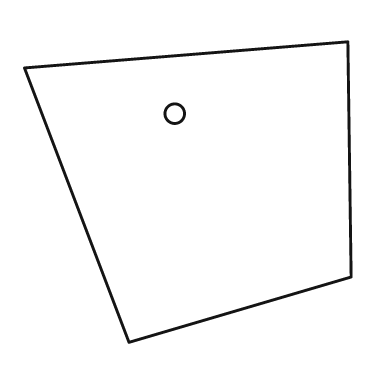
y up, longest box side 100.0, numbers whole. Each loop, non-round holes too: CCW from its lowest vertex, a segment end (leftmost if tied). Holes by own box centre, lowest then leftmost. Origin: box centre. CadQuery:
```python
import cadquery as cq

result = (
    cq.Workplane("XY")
    .moveTo(-18.0, -46.0)
    .lineTo(50.0, -26.0)
    .lineTo(49.0, 46.0)
    .lineTo(-50.0, 38.0)
    .close()
    .moveTo(-4.0, 24.0)
    .circle(3.0)
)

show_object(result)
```